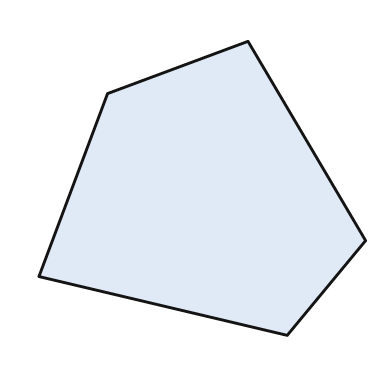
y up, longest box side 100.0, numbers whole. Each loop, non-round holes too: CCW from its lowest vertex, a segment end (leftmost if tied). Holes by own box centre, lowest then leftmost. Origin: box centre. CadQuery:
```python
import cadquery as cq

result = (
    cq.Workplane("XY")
    .moveTo(26.0, -45.0)
    .lineTo(50.0, -16.0)
    .lineTo(14.0, 45.0)
    .lineTo(-29.0, 29.0)
    .lineTo(-50.0, -27.0)
    .close()
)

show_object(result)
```